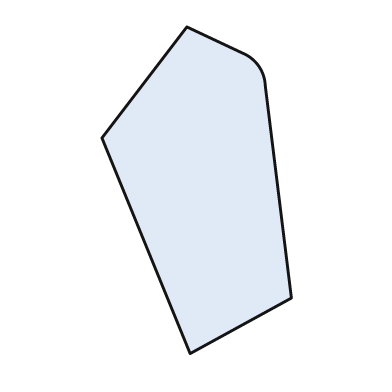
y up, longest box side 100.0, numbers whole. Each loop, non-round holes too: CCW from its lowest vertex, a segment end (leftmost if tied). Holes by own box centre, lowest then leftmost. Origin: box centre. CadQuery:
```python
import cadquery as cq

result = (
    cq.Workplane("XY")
    .moveTo(-2.0, -50.0)
    .lineTo(29.0, -33.0)
    .lineTo(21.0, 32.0)
    .threePointArc((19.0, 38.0), (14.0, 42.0))
    .lineTo(-3.0, 50.0)
    .lineTo(-29.0, 16.0)
    .close()
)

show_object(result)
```